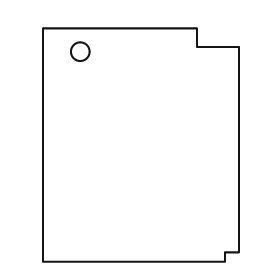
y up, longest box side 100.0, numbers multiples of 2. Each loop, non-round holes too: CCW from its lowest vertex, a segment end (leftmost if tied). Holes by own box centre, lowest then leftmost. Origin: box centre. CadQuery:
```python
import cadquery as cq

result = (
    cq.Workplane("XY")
    .moveTo(-42.0, -50.0)
    .lineTo(36.0, -50.0)
    .lineTo(36.0, -46.0)
    .lineTo(42.0, -46.0)
    .lineTo(42.0, 42.0)
    .lineTo(24.0, 42.0)
    .lineTo(24.0, 50.0)
    .lineTo(-42.0, 50.0)
    .close()
    .moveTo(-26.0, 40.0)
    .circle(4.0)
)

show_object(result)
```